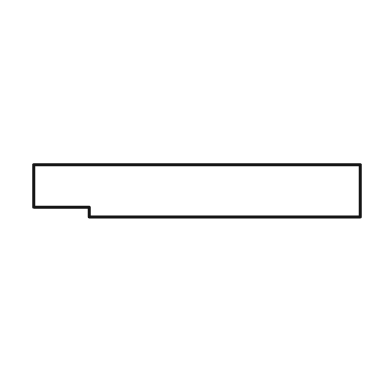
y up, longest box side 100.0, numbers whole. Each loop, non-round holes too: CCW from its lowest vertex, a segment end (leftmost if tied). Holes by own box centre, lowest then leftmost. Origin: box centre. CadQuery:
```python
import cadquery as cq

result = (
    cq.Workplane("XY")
    .moveTo(-33.0, -8.0)
    .lineTo(50.0, -8.0)
    .lineTo(50.0, 8.0)
    .lineTo(-50.0, 8.0)
    .lineTo(-50.0, -5.0)
    .lineTo(-33.0, -5.0)
    .close()
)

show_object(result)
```